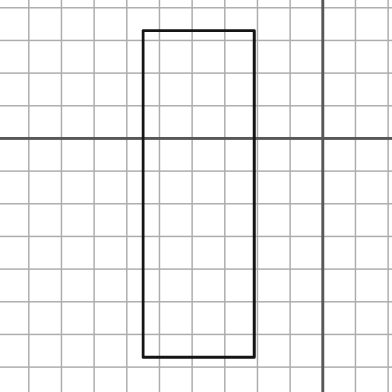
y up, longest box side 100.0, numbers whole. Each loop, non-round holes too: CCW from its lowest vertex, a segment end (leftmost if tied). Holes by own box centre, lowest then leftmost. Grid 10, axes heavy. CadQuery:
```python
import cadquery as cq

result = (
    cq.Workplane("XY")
    .moveTo(-55.0, -67.0)
    .lineTo(-21.0, -67.0)
    .lineTo(-21.0, 33.0)
    .lineTo(-55.0, 33.0)
    .close()
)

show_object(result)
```